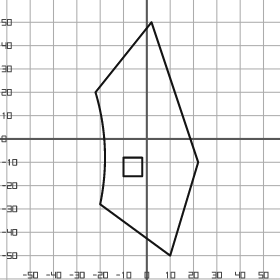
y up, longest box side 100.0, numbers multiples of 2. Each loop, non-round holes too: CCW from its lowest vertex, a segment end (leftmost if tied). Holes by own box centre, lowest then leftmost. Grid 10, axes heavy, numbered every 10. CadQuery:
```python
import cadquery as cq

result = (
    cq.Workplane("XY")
    .moveTo(10.0, -50.0)
    .lineTo(22.0, -10.0)
    .lineTo(2.0, 50.0)
    .lineTo(-22.0, 20.0)
    .threePointArc((-18.0, -4.0), (-20.0, -28.0))
    .close()
    .moveTo(-10.0, -16.0)
    .lineTo(-2.0, -16.0)
    .lineTo(-2.0, -8.0)
    .lineTo(-10.0, -8.0)
    .close()
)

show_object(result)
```